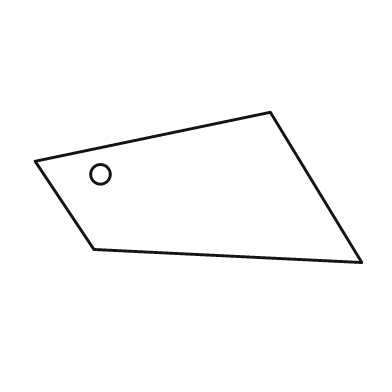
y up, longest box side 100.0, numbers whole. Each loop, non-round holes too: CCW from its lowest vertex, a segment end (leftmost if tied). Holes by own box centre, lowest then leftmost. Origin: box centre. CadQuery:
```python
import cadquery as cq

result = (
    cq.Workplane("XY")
    .moveTo(50.0, -23.0)
    .lineTo(22.0, 23.0)
    .lineTo(-50.0, 8.0)
    .lineTo(-32.0, -19.0)
    .close()
    .moveTo(-30.0, 4.0)
    .circle(3.0)
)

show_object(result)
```